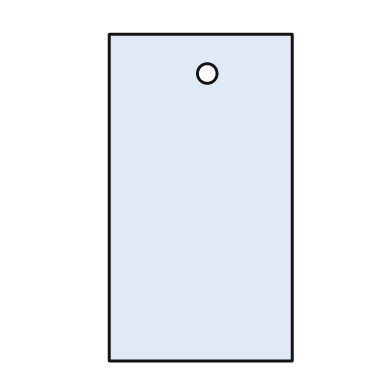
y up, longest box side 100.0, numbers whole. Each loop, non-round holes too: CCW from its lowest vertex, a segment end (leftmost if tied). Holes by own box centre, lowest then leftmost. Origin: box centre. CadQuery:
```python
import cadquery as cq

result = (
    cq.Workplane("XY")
    .moveTo(-28.0, -50.0)
    .lineTo(28.0, -50.0)
    .lineTo(28.0, 50.0)
    .lineTo(-28.0, 50.0)
    .close()
    .moveTo(2.0, 38.0)
    .circle(3.0)
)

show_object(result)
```